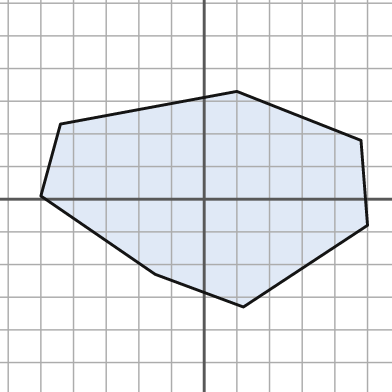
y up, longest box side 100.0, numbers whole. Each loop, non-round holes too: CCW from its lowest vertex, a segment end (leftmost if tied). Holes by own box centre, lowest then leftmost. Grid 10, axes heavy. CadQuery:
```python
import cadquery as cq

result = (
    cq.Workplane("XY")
    .moveTo(12.0, -33.0)
    .lineTo(50.0, -8.0)
    .lineTo(48.0, 18.0)
    .lineTo(10.0, 33.0)
    .lineTo(-44.0, 23.0)
    .lineTo(-50.0, 1.0)
    .lineTo(-15.0, -23.0)
    .close()
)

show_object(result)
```